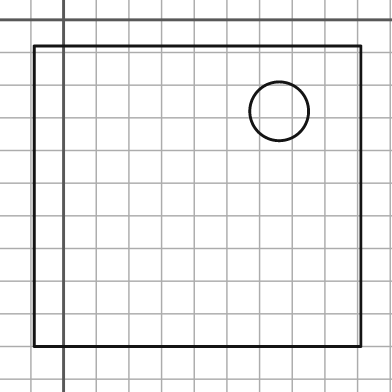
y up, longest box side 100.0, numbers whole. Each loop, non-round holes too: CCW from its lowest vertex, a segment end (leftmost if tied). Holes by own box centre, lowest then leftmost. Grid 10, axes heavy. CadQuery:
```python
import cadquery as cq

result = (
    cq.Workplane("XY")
    .moveTo(-9.0, -100.0)
    .lineTo(91.0, -100.0)
    .lineTo(91.0, -8.0)
    .lineTo(-9.0, -8.0)
    .close()
    .moveTo(66.0, -28.0)
    .circle(9.0)
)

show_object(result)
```